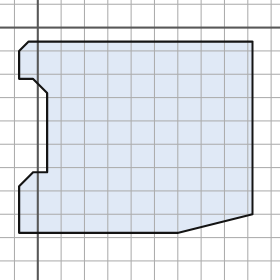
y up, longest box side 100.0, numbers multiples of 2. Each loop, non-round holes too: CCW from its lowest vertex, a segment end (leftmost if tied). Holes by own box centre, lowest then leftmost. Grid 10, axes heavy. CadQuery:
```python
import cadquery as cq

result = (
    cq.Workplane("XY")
    .moveTo(-8.0, -88.0)
    .lineTo(60.0, -88.0)
    .lineTo(92.0, -80.0)
    .lineTo(92.0, -6.0)
    .lineTo(-4.0, -6.0)
    .lineTo(-8.0, -10.0)
    .lineTo(-8.0, -22.0)
    .lineTo(-2.0, -22.0)
    .lineTo(4.0, -28.0)
    .lineTo(4.0, -62.0)
    .lineTo(-2.0, -62.0)
    .lineTo(-8.0, -68.0)
    .close()
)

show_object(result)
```